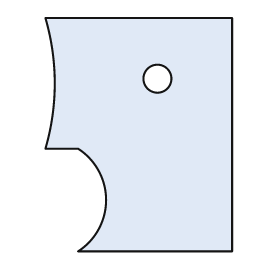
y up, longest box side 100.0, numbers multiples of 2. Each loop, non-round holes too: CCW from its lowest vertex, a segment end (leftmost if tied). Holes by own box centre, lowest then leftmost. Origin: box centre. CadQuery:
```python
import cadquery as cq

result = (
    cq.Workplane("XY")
    .moveTo(-26.0, -50.0)
    .lineTo(40.0, -50.0)
    .lineTo(40.0, 50.0)
    .lineTo(-40.0, 50.0)
    .threePointArc((-36.0, 22.0), (-40.0, -6.0))
    .lineTo(-26.0, -6.0)
    .threePointArc((-14.0, -28.0), (-26.0, -50.0))
    .close()
    .moveTo(8.0, 24.0)
    .circle(6.0)
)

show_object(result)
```